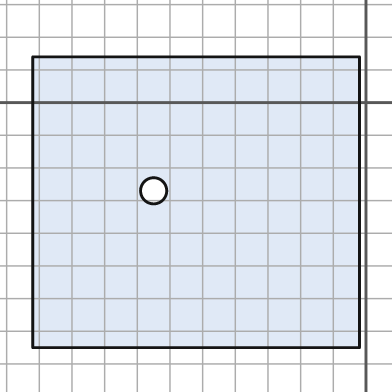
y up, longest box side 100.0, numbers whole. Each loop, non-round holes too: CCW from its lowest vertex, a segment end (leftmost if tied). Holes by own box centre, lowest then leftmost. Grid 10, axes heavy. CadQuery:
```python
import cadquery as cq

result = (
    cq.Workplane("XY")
    .moveTo(-102.0, -75.0)
    .lineTo(-2.0, -75.0)
    .lineTo(-2.0, 14.0)
    .lineTo(-102.0, 14.0)
    .close()
    .moveTo(-65.0, -27.0)
    .circle(4.0)
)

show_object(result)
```